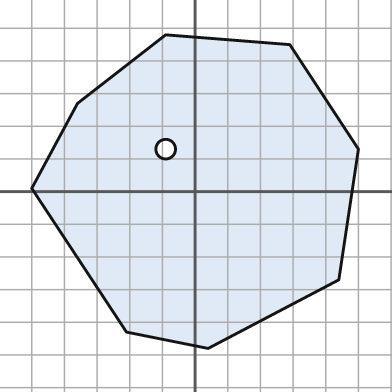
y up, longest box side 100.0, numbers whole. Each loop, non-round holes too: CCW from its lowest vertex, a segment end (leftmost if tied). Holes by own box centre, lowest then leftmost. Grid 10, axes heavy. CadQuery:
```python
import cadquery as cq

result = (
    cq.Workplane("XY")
    .moveTo(4.0, -48.0)
    .lineTo(44.0, -27.0)
    .lineTo(50.0, 13.0)
    .lineTo(29.0, 45.0)
    .lineTo(-9.0, 48.0)
    .lineTo(-36.0, 27.0)
    .lineTo(-50.0, 1.0)
    .lineTo(-21.0, -43.0)
    .close()
    .moveTo(-9.0, 13.0)
    .circle(3.0)
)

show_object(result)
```